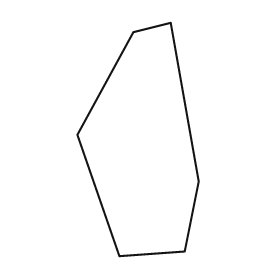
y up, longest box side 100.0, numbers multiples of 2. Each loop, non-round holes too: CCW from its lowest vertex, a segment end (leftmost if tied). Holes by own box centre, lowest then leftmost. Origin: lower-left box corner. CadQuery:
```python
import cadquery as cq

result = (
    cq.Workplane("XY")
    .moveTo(18.0, 0.0)
    .lineTo(46.0, 2.0)
    .lineTo(52.0, 32.0)
    .lineTo(40.0, 100.0)
    .lineTo(24.0, 96.0)
    .lineTo(0.0, 52.0)
    .close()
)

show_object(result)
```